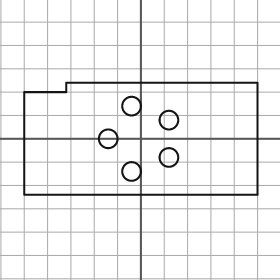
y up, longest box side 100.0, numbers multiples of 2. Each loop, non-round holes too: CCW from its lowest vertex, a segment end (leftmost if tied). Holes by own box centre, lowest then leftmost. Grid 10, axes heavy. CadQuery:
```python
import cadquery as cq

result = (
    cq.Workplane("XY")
    .moveTo(-50.0, -24.0)
    .lineTo(50.0, -24.0)
    .lineTo(50.0, 24.0)
    .lineTo(-32.0, 24.0)
    .lineTo(-32.0, 20.0)
    .lineTo(-50.0, 20.0)
    .close()
    .moveTo(-4.0, -14.0)
    .circle(4.0)
    .moveTo(12.0, -8.0)
    .circle(4.0)
    .moveTo(-14.0, 0.0)
    .circle(4.0)
    .moveTo(12.0, 8.0)
    .circle(4.0)
    .moveTo(-4.0, 14.0)
    .circle(4.0)
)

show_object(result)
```